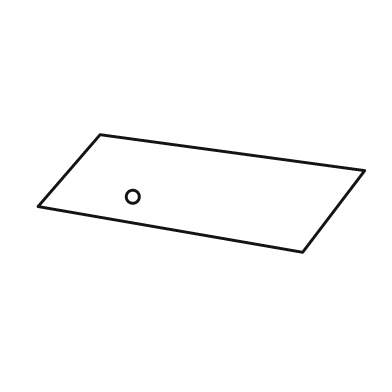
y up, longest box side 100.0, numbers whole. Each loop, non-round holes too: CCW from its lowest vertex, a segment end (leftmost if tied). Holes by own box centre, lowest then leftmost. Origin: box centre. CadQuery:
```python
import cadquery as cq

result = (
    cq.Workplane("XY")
    .moveTo(31.0, -18.0)
    .lineTo(50.0, 7.0)
    .lineTo(-31.0, 18.0)
    .lineTo(-50.0, -4.0)
    .close()
    .moveTo(-21.0, -1.0)
    .circle(2.0)
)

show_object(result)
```